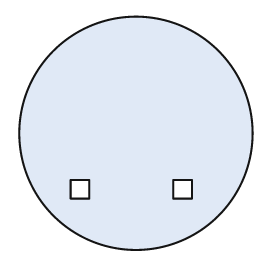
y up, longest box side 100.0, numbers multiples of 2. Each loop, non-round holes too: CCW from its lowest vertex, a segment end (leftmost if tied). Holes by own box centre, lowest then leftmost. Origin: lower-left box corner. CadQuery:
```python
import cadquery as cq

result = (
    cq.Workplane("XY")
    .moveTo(50.0, 50.0)
    .circle(50.0)
    .moveTo(22.0, 22.0)
    .lineTo(30.0, 22.0)
    .lineTo(30.0, 30.0)
    .lineTo(22.0, 30.0)
    .close()
    .moveTo(66.0, 22.0)
    .lineTo(74.0, 22.0)
    .lineTo(74.0, 30.0)
    .lineTo(66.0, 30.0)
    .close()
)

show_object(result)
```